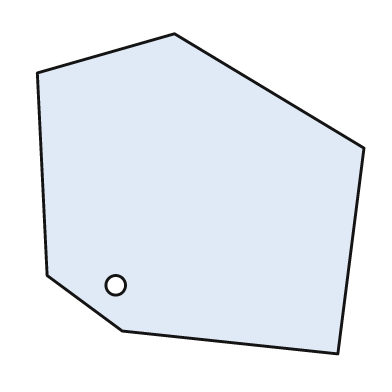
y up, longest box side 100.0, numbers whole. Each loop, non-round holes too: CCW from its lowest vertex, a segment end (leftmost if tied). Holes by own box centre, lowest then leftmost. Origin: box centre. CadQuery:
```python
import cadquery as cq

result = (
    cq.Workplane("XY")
    .moveTo(42.0, -49.0)
    .lineTo(50.0, 14.0)
    .lineTo(-8.0, 49.0)
    .lineTo(-50.0, 37.0)
    .lineTo(-47.0, -25.0)
    .lineTo(-24.0, -42.0)
    .close()
    .moveTo(-26.0, -28.0)
    .circle(3.0)
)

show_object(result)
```